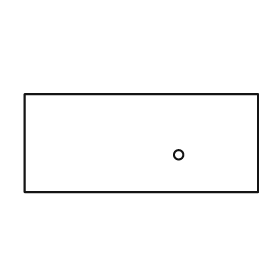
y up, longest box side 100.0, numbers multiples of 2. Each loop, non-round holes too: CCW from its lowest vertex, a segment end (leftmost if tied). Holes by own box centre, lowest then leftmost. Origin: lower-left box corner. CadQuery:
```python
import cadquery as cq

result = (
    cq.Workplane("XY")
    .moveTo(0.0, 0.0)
    .lineTo(100.0, 0.0)
    .lineTo(100.0, 42.0)
    .lineTo(0.0, 42.0)
    .close()
    .moveTo(66.0, 16.0)
    .circle(2.0)
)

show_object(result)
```